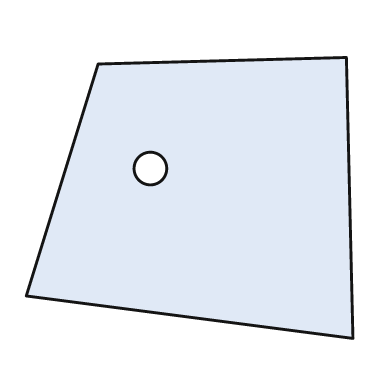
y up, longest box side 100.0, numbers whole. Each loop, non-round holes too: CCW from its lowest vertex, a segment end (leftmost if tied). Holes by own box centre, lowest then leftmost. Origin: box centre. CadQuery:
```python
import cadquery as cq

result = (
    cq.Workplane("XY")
    .moveTo(50.0, -43.0)
    .lineTo(48.0, 43.0)
    .lineTo(-28.0, 41.0)
    .lineTo(-50.0, -30.0)
    .close()
    .moveTo(-12.0, 9.0)
    .circle(5.0)
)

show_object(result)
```